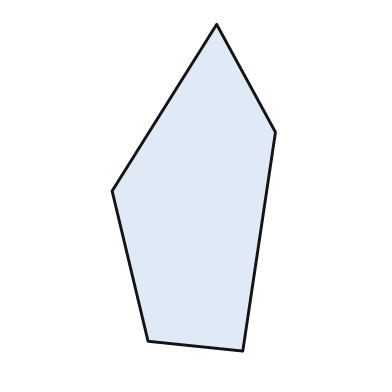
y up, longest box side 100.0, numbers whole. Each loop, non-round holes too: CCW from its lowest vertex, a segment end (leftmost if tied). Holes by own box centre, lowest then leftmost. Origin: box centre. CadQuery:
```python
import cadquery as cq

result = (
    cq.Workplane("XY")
    .moveTo(15.0, -50.0)
    .lineTo(25.0, 17.0)
    .lineTo(7.0, 50.0)
    .lineTo(-25.0, -1.0)
    .lineTo(-14.0, -47.0)
    .close()
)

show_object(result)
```